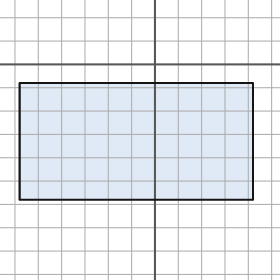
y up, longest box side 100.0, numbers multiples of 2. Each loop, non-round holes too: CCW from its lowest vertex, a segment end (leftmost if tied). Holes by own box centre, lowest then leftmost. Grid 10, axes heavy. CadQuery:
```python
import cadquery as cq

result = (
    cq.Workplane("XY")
    .moveTo(-58.0, -58.0)
    .lineTo(42.0, -58.0)
    .lineTo(42.0, -8.0)
    .lineTo(-58.0, -8.0)
    .close()
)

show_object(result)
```